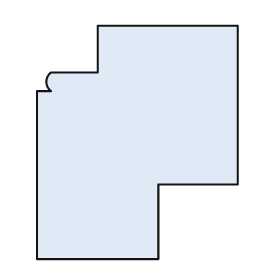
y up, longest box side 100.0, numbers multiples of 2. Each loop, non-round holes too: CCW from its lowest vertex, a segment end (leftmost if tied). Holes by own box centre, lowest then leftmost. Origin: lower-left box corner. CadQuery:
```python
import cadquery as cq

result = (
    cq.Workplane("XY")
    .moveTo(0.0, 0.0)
    .lineTo(52.0, 0.0)
    .lineTo(52.0, 32.0)
    .lineTo(86.0, 32.0)
    .lineTo(86.0, 100.0)
    .lineTo(26.0, 100.0)
    .lineTo(26.0, 80.0)
    .lineTo(6.0, 80.0)
    .threePointArc((4.0, 76.0), (6.0, 72.0))
    .lineTo(0.0, 72.0)
    .close()
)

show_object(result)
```